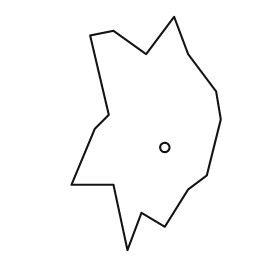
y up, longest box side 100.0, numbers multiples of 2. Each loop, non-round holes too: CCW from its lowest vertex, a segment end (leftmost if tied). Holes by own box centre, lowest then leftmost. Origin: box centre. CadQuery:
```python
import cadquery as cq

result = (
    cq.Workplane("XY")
    .moveTo(-8.0, -50.0)
    .lineTo(-2.0, -34.0)
    .lineTo(8.0, -40.0)
    .lineTo(18.0, -24.0)
    .lineTo(26.0, -18.0)
    .lineTo(32.0, 6.0)
    .lineTo(30.0, 18.0)
    .lineTo(18.0, 34.0)
    .lineTo(12.0, 50.0)
    .lineTo(0.0, 34.0)
    .lineTo(-14.0, 44.0)
    .lineTo(-24.0, 42.0)
    .lineTo(-16.0, 8.0)
    .lineTo(-22.0, 2.0)
    .lineTo(-32.0, -22.0)
    .lineTo(-14.0, -22.0)
    .close()
    .moveTo(8.0, -6.0)
    .circle(2.0)
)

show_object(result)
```